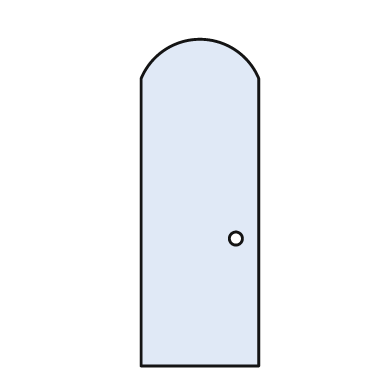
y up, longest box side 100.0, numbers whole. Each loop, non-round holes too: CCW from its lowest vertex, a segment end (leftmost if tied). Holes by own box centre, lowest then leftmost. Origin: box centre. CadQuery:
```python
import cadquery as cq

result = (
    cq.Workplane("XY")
    .moveTo(-18.0, -50.0)
    .lineTo(18.0, -50.0)
    .lineTo(18.0, 38.0)
    .threePointArc((0.0, 50.0), (-18.0, 38.0))
    .close()
    .moveTo(11.0, -11.0)
    .circle(2.0)
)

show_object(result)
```